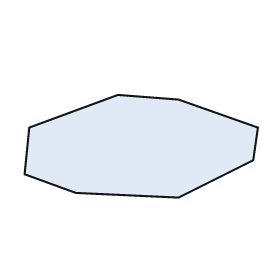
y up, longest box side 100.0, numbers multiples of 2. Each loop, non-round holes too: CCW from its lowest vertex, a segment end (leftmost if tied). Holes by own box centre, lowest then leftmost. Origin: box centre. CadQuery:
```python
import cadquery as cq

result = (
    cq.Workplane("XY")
    .moveTo(16.0, -22.0)
    .lineTo(48.0, -6.0)
    .lineTo(50.0, 8.0)
    .lineTo(16.0, 20.0)
    .lineTo(-10.0, 22.0)
    .lineTo(-48.0, 8.0)
    .lineTo(-50.0, -12.0)
    .lineTo(-28.0, -20.0)
    .close()
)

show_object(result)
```